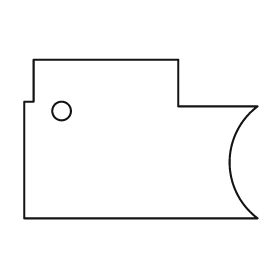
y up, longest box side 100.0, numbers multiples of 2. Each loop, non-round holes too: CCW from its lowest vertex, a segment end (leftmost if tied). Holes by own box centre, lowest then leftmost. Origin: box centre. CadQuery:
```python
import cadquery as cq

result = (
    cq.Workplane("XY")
    .moveTo(-50.0, -34.0)
    .lineTo(50.0, -34.0)
    .threePointArc((38.0, -10.0), (50.0, 14.0))
    .lineTo(16.0, 14.0)
    .lineTo(16.0, 34.0)
    .lineTo(-46.0, 34.0)
    .lineTo(-46.0, 16.0)
    .lineTo(-50.0, 16.0)
    .close()
    .moveTo(-34.0, 12.0)
    .circle(4.0)
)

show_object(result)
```